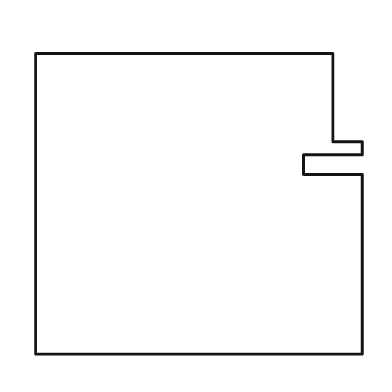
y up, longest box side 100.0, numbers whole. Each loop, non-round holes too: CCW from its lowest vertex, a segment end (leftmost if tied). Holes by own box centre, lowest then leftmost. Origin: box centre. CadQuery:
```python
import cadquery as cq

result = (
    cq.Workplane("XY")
    .moveTo(-50.0, -46.0)
    .lineTo(50.0, -46.0)
    .lineTo(50.0, 9.0)
    .lineTo(32.0, 9.0)
    .lineTo(32.0, 15.0)
    .lineTo(50.0, 15.0)
    .lineTo(50.0, 19.0)
    .lineTo(41.0, 19.0)
    .lineTo(41.0, 46.0)
    .lineTo(-50.0, 46.0)
    .close()
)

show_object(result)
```